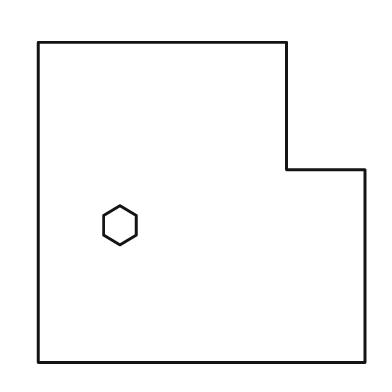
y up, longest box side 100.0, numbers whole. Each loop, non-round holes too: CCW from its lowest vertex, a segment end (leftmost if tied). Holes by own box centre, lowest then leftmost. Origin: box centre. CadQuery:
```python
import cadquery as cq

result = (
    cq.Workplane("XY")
    .moveTo(-50.0, -49.0)
    .lineTo(50.0, -49.0)
    .lineTo(50.0, 10.0)
    .lineTo(26.0, 10.0)
    .lineTo(26.0, 49.0)
    .lineTo(-50.0, 49.0)
    .close()
    .moveTo(-25.0, -13.0)
    .lineTo(-20.0, -10.0)
    .lineTo(-20.0, -4.0)
    .lineTo(-25.0, -1.0)
    .lineTo(-30.0, -4.0)
    .lineTo(-30.0, -10.0)
    .close()
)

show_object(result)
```